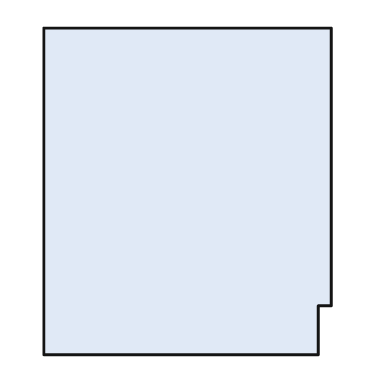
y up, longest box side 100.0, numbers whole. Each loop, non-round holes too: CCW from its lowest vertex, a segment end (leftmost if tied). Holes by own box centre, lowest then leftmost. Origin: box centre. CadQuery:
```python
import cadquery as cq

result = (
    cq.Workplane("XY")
    .moveTo(-44.0, -50.0)
    .lineTo(40.0, -50.0)
    .lineTo(40.0, -35.0)
    .lineTo(44.0, -35.0)
    .lineTo(44.0, 50.0)
    .lineTo(-44.0, 50.0)
    .close()
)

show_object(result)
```